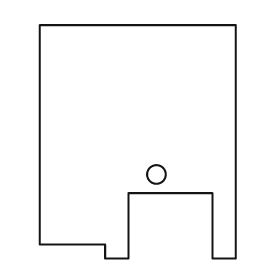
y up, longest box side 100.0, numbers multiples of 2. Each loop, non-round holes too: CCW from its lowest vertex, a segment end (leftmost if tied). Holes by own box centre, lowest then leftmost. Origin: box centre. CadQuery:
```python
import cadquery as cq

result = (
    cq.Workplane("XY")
    .moveTo(-14.0, -50.0)
    .lineTo(-4.0, -50.0)
    .lineTo(-4.0, -22.0)
    .lineTo(32.0, -22.0)
    .lineTo(32.0, -50.0)
    .lineTo(42.0, -50.0)
    .lineTo(42.0, 50.0)
    .lineTo(-42.0, 50.0)
    .lineTo(-42.0, -44.0)
    .lineTo(-14.0, -44.0)
    .close()
    .moveTo(8.0, -14.0)
    .circle(4.0)
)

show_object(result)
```